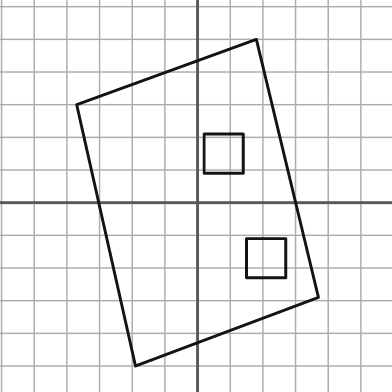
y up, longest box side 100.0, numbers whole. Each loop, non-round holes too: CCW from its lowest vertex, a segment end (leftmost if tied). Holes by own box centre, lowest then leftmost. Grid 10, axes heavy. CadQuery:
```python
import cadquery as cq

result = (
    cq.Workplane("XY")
    .moveTo(-19.0, -50.0)
    .lineTo(37.0, -29.0)
    .lineTo(18.0, 50.0)
    .lineTo(-37.0, 30.0)
    .close()
    .moveTo(15.0, -23.0)
    .lineTo(27.0, -23.0)
    .lineTo(27.0, -11.0)
    .lineTo(15.0, -11.0)
    .close()
    .moveTo(2.0, 9.0)
    .lineTo(14.0, 9.0)
    .lineTo(14.0, 21.0)
    .lineTo(2.0, 21.0)
    .close()
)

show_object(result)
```